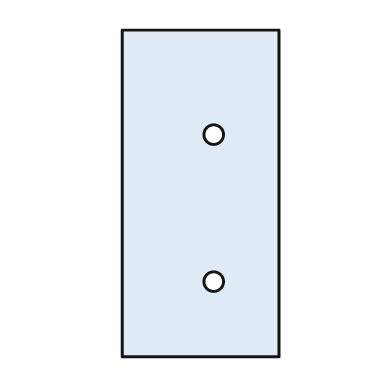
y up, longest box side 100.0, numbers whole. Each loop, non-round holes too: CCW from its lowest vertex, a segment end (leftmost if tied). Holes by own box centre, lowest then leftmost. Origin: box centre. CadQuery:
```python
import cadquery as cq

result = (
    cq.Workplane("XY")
    .moveTo(-24.0, -50.0)
    .lineTo(24.0, -50.0)
    .lineTo(24.0, 50.0)
    .lineTo(-24.0, 50.0)
    .close()
    .moveTo(4.0, -27.0)
    .circle(3.0)
    .moveTo(4.0, 18.0)
    .circle(3.0)
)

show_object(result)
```